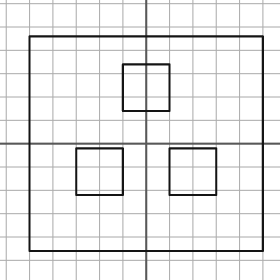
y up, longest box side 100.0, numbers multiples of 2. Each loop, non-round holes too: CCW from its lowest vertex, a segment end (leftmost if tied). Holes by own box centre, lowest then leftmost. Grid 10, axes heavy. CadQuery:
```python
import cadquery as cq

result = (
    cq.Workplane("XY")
    .moveTo(-50.0, -46.0)
    .lineTo(50.0, -46.0)
    .lineTo(50.0, 46.0)
    .lineTo(-50.0, 46.0)
    .close()
    .moveTo(-30.0, -22.0)
    .lineTo(-10.0, -22.0)
    .lineTo(-10.0, -2.0)
    .lineTo(-30.0, -2.0)
    .close()
    .moveTo(10.0, -22.0)
    .lineTo(30.0, -22.0)
    .lineTo(30.0, -2.0)
    .lineTo(10.0, -2.0)
    .close()
    .moveTo(-10.0, 14.0)
    .lineTo(10.0, 14.0)
    .lineTo(10.0, 34.0)
    .lineTo(-10.0, 34.0)
    .close()
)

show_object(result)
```